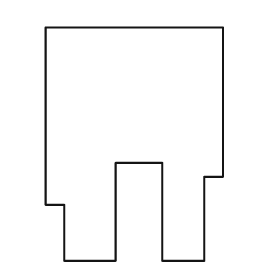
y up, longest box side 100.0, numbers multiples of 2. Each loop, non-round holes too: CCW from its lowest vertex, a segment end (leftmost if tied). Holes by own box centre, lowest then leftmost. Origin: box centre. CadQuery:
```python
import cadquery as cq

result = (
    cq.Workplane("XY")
    .moveTo(-30.0, -50.0)
    .lineTo(-8.0, -50.0)
    .lineTo(-8.0, -8.0)
    .lineTo(12.0, -8.0)
    .lineTo(12.0, -50.0)
    .lineTo(30.0, -50.0)
    .lineTo(30.0, -14.0)
    .lineTo(38.0, -14.0)
    .lineTo(38.0, 50.0)
    .lineTo(-38.0, 50.0)
    .lineTo(-38.0, -26.0)
    .lineTo(-30.0, -26.0)
    .close()
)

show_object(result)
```